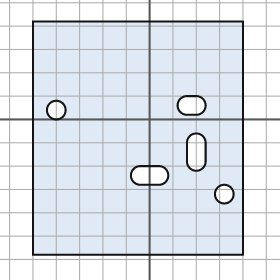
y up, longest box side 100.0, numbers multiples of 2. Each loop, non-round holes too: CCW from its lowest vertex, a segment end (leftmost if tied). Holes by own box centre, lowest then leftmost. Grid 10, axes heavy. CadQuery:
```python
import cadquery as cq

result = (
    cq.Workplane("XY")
    .moveTo(-50.0, -58.0)
    .lineTo(40.0, -58.0)
    .lineTo(40.0, 42.0)
    .lineTo(-50.0, 42.0)
    .close()
    .moveTo(32.0, -32.0)
    .circle(4.0)
    .moveTo(-4.0, -28.0)
    .lineTo(4.0, -28.0)
    .threePointArc((8.0, -24.0), (4.0, -20.0))
    .lineTo(-4.0, -20.0)
    .threePointArc((-8.0, -24.0), (-4.0, -28.0))
    .close()
    .moveTo(16.0, -18.0)
    .threePointArc((20.0, -22.0), (24.0, -18.0))
    .lineTo(24.0, -10.0)
    .threePointArc((20.0, -6.0), (16.0, -10.0))
    .close()
    .moveTo(-40.0, 4.0)
    .circle(4.0)
    .moveTo(16.0, 2.0)
    .lineTo(20.0, 2.0)
    .threePointArc((24.0, 6.0), (20.0, 10.0))
    .lineTo(16.0, 10.0)
    .threePointArc((12.0, 6.0), (16.0, 2.0))
    .close()
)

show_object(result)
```